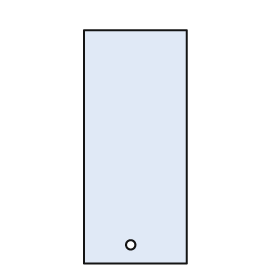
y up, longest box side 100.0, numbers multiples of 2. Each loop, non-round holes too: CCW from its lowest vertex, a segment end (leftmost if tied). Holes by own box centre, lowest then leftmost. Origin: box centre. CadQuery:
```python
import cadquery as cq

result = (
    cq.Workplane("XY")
    .moveTo(-22.0, -50.0)
    .lineTo(22.0, -50.0)
    .lineTo(22.0, 50.0)
    .lineTo(-22.0, 50.0)
    .close()
    .moveTo(-2.0, -42.0)
    .circle(2.0)
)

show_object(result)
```